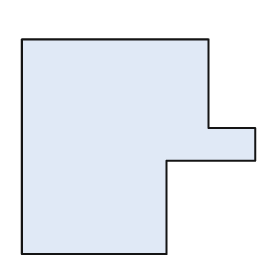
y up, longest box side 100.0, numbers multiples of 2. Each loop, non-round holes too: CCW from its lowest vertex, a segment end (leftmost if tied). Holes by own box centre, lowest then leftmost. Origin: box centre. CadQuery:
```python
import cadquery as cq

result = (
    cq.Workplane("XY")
    .moveTo(-50.0, -46.0)
    .lineTo(12.0, -46.0)
    .lineTo(12.0, -6.0)
    .lineTo(50.0, -6.0)
    .lineTo(50.0, 8.0)
    .lineTo(30.0, 8.0)
    .lineTo(30.0, 46.0)
    .lineTo(-50.0, 46.0)
    .close()
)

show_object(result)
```